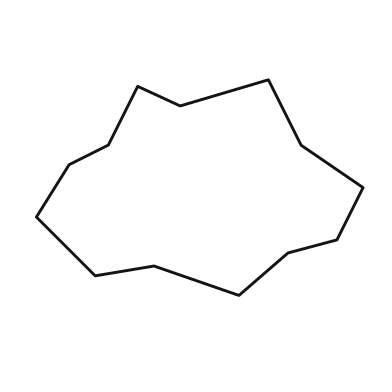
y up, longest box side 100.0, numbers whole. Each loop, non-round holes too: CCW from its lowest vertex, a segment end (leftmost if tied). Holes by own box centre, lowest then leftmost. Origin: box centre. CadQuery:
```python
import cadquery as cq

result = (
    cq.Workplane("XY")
    .moveTo(12.0, -33.0)
    .lineTo(27.0, -20.0)
    .lineTo(42.0, -16.0)
    .lineTo(50.0, 0.0)
    .lineTo(31.0, 13.0)
    .lineTo(21.0, 33.0)
    .lineTo(-6.0, 25.0)
    .lineTo(-19.0, 31.0)
    .lineTo(-28.0, 13.0)
    .lineTo(-40.0, 7.0)
    .lineTo(-50.0, -9.0)
    .lineTo(-32.0, -27.0)
    .lineTo(-14.0, -24.0)
    .close()
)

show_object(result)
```